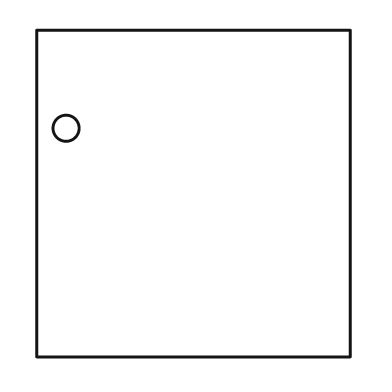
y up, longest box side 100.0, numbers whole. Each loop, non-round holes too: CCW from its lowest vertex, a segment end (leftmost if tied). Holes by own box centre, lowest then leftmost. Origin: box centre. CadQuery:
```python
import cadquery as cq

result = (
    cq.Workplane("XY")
    .moveTo(-48.0, -50.0)
    .lineTo(48.0, -50.0)
    .lineTo(48.0, 50.0)
    .lineTo(-48.0, 50.0)
    .close()
    .moveTo(-39.0, 20.0)
    .circle(4.0)
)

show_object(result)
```